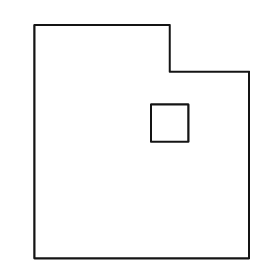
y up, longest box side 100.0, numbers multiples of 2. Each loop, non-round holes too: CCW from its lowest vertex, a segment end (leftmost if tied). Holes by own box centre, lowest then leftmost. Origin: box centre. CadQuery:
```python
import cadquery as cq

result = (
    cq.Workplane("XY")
    .moveTo(-46.0, -50.0)
    .lineTo(46.0, -50.0)
    .lineTo(46.0, 30.0)
    .lineTo(12.0, 30.0)
    .lineTo(12.0, 50.0)
    .lineTo(-46.0, 50.0)
    .close()
    .moveTo(4.0, 0.0)
    .lineTo(20.0, 0.0)
    .lineTo(20.0, 16.0)
    .lineTo(4.0, 16.0)
    .close()
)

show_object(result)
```